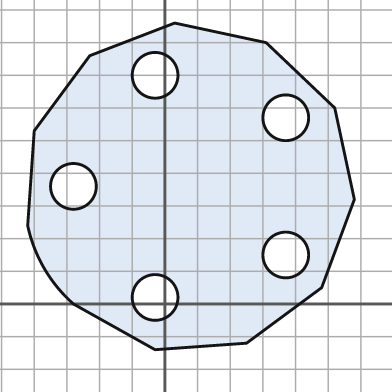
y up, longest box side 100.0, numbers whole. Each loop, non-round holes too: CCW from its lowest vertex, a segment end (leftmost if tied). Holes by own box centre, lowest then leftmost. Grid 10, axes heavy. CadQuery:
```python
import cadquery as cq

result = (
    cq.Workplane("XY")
    .moveTo(-3.0, -14.0)
    .lineTo(25.0, -12.0)
    .lineTo(48.0, 5.0)
    .lineTo(58.0, 32.0)
    .lineTo(52.0, 60.0)
    .lineTo(31.0, 80.0)
    .lineTo(3.0, 86.0)
    .lineTo(-23.0, 76.0)
    .lineTo(-40.0, 53.0)
    .lineTo(-42.0, 24.0)
    .threePointArc((-37.0, 11.0), (-28.0, 0.0))
    .close()
    .moveTo(-3.0, 2.0)
    .circle(7.0)
    .moveTo(37.0, 15.0)
    .circle(7.0)
    .moveTo(-28.0, 36.0)
    .circle(7.0)
    .moveTo(37.0, 57.0)
    .circle(7.0)
    .moveTo(-3.0, 70.0)
    .circle(7.0)
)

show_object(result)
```